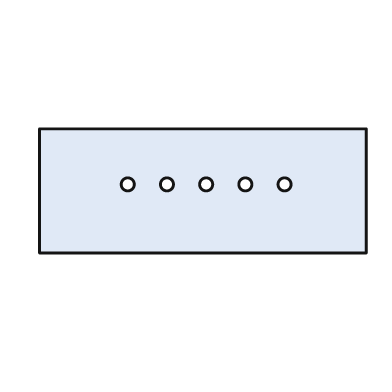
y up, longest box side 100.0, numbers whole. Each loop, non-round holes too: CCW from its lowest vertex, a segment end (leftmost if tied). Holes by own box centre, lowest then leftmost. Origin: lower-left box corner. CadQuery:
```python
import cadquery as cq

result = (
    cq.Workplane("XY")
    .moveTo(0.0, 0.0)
    .lineTo(100.0, 0.0)
    .lineTo(100.0, 38.0)
    .lineTo(0.0, 38.0)
    .close()
    .moveTo(27.0, 21.0)
    .circle(2.0)
    .moveTo(39.0, 21.0)
    .circle(2.0)
    .moveTo(51.0, 21.0)
    .circle(2.0)
    .moveTo(63.0, 21.0)
    .circle(2.0)
    .moveTo(75.0, 21.0)
    .circle(2.0)
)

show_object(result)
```